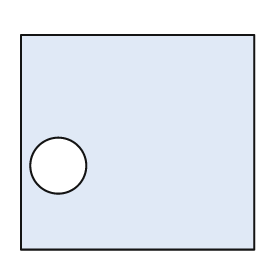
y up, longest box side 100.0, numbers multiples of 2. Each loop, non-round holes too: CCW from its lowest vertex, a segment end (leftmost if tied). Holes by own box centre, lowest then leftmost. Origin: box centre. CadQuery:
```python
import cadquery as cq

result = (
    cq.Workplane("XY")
    .moveTo(-50.0, -46.0)
    .lineTo(50.0, -46.0)
    .lineTo(50.0, 46.0)
    .lineTo(-50.0, 46.0)
    .close()
    .moveTo(-34.0, -10.0)
    .circle(12.0)
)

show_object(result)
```